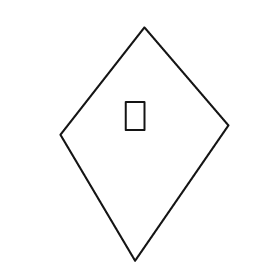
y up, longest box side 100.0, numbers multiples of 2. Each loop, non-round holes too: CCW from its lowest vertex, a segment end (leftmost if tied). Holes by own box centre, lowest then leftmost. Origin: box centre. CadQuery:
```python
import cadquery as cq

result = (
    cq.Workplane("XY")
    .moveTo(-4.0, -50.0)
    .lineTo(36.0, 8.0)
    .lineTo(0.0, 50.0)
    .lineTo(-36.0, 4.0)
    .close()
    .moveTo(-8.0, 6.0)
    .lineTo(0.0, 6.0)
    .lineTo(0.0, 18.0)
    .lineTo(-8.0, 18.0)
    .close()
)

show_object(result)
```